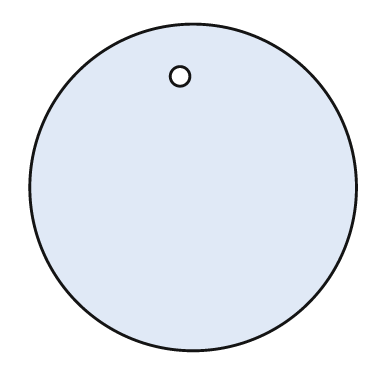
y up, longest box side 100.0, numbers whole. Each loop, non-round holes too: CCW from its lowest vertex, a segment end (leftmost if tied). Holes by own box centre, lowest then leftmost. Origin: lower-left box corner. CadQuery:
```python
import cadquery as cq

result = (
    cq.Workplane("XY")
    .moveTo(50.0, 50.0)
    .circle(50.0)
    .moveTo(46.0, 84.0)
    .circle(3.0)
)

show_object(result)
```